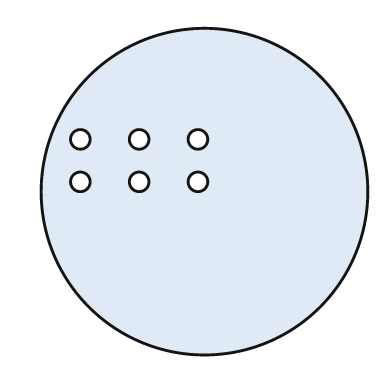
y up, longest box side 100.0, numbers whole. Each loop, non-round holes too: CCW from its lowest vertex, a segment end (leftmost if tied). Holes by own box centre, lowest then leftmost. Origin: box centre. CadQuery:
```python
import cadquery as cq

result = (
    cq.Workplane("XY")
    .moveTo(0.0, 0.0)
    .circle(50.0)
    .moveTo(-38.0, 3.0)
    .circle(3.0)
    .moveTo(-20.0, 3.0)
    .circle(3.0)
    .moveTo(-2.0, 3.0)
    .circle(3.0)
    .moveTo(-38.0, 16.0)
    .circle(3.0)
    .moveTo(-20.0, 16.0)
    .circle(3.0)
    .moveTo(-2.0, 16.0)
    .circle(3.0)
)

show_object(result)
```